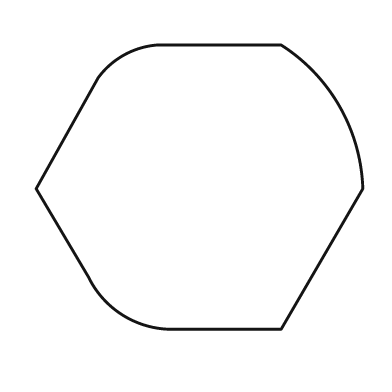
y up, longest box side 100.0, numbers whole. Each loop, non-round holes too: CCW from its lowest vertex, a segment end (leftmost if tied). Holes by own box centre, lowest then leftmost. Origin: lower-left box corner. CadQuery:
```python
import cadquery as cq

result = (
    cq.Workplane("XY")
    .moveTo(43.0, 0.0)
    .lineTo(75.0, 0.0)
    .lineTo(100.0, 43.0)
    .threePointArc((93.0, 68.0), (75.0, 87.0))
    .lineTo(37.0, 87.0)
    .threePointArc((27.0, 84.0), (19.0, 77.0))
    .lineTo(0.0, 43.0)
    .lineTo(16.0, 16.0)
    .threePointArc((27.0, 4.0), (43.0, 0.0))
    .close()
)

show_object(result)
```